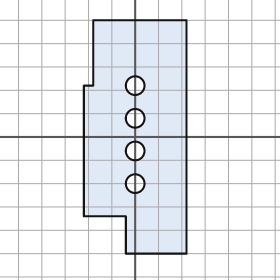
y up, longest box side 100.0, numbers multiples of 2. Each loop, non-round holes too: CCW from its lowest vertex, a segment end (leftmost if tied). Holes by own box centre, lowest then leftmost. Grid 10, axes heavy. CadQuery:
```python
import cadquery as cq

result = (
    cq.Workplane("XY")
    .moveTo(-4.0, -50.0)
    .lineTo(22.0, -50.0)
    .lineTo(22.0, 50.0)
    .lineTo(-18.0, 50.0)
    .lineTo(-18.0, 22.0)
    .lineTo(-22.0, 22.0)
    .lineTo(-22.0, -34.0)
    .lineTo(-4.0, -34.0)
    .close()
    .moveTo(0.0, -20.0)
    .circle(4.0)
    .moveTo(0.0, -6.0)
    .circle(4.0)
    .moveTo(0.0, 8.0)
    .circle(4.0)
    .moveTo(0.0, 22.0)
    .circle(4.0)
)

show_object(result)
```